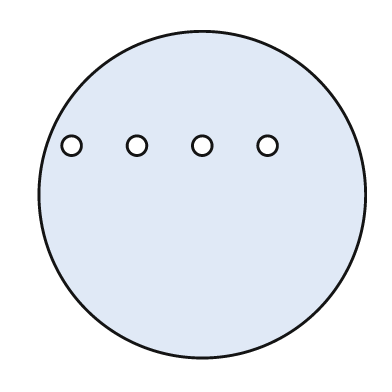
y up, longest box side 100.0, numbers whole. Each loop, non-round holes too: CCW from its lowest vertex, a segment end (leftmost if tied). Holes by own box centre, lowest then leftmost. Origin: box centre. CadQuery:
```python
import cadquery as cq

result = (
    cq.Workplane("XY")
    .moveTo(0.0, 0.0)
    .circle(50.0)
    .moveTo(-40.0, 15.0)
    .circle(3.0)
    .moveTo(-20.0, 15.0)
    .circle(3.0)
    .moveTo(0.0, 15.0)
    .circle(3.0)
    .moveTo(20.0, 15.0)
    .circle(3.0)
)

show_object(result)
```